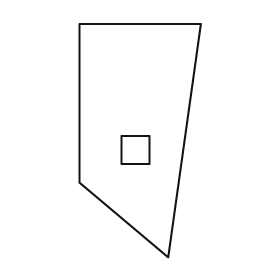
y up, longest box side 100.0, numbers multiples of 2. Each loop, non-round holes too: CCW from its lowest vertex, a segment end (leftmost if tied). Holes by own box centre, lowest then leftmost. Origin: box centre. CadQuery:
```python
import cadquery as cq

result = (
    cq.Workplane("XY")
    .moveTo(12.0, -50.0)
    .lineTo(26.0, 50.0)
    .lineTo(-26.0, 50.0)
    .lineTo(-26.0, -18.0)
    .close()
    .moveTo(-8.0, -10.0)
    .lineTo(4.0, -10.0)
    .lineTo(4.0, 2.0)
    .lineTo(-8.0, 2.0)
    .close()
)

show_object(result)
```